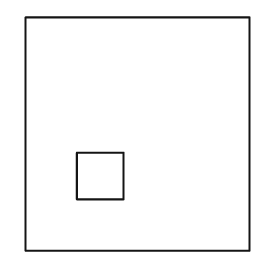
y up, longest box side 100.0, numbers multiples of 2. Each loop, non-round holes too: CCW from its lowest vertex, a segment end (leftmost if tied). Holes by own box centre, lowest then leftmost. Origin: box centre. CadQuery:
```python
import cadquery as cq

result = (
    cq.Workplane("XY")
    .moveTo(-48.0, -50.0)
    .lineTo(48.0, -50.0)
    .lineTo(48.0, 50.0)
    .lineTo(-48.0, 50.0)
    .close()
    .moveTo(-26.0, -28.0)
    .lineTo(-6.0, -28.0)
    .lineTo(-6.0, -8.0)
    .lineTo(-26.0, -8.0)
    .close()
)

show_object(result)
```